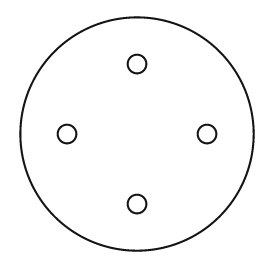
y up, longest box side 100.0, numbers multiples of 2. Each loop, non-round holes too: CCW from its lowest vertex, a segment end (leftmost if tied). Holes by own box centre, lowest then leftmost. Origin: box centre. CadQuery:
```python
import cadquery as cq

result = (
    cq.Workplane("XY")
    .moveTo(0.0, 0.0)
    .circle(50.0)
    .moveTo(0.0, -30.0)
    .circle(4.0)
    .moveTo(-30.0, 0.0)
    .circle(4.0)
    .moveTo(30.0, 0.0)
    .circle(4.0)
    .moveTo(0.0, 30.0)
    .circle(4.0)
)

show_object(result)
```